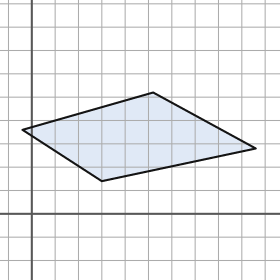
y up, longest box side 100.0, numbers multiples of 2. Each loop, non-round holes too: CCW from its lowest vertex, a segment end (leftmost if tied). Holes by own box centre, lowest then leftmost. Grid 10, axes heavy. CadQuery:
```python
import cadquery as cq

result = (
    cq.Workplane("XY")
    .moveTo(30.0, 14.0)
    .lineTo(96.0, 28.0)
    .lineTo(52.0, 52.0)
    .lineTo(-4.0, 36.0)
    .close()
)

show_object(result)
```